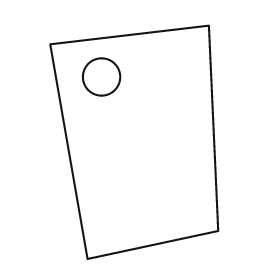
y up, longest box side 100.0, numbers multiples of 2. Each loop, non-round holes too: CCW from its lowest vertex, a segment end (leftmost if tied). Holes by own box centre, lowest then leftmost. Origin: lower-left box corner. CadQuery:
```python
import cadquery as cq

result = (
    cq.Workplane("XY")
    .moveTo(16.0, 0.0)
    .lineTo(72.0, 12.0)
    .lineTo(68.0, 100.0)
    .lineTo(0.0, 92.0)
    .close()
    .moveTo(22.0, 78.0)
    .circle(8.0)
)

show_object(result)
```